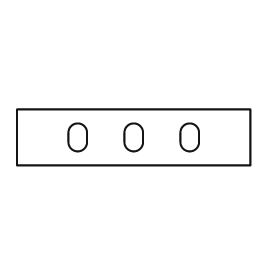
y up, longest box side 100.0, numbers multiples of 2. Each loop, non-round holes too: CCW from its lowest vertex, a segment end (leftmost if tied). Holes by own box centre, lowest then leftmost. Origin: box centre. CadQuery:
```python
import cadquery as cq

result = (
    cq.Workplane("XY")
    .moveTo(-50.0, -12.0)
    .lineTo(50.0, -12.0)
    .lineTo(50.0, 12.0)
    .lineTo(-50.0, 12.0)
    .close()
    .moveTo(-28.0, -2.0)
    .threePointArc((-24.0, -6.0), (-20.0, -2.0))
    .lineTo(-20.0, 2.0)
    .threePointArc((-24.0, 6.0), (-28.0, 2.0))
    .close()
    .moveTo(-4.0, -2.0)
    .threePointArc((0.0, -6.0), (4.0, -2.0))
    .lineTo(4.0, 2.0)
    .threePointArc((0.0, 6.0), (-4.0, 2.0))
    .close()
    .moveTo(20.0, -2.0)
    .threePointArc((24.0, -6.0), (28.0, -2.0))
    .lineTo(28.0, 2.0)
    .threePointArc((24.0, 6.0), (20.0, 2.0))
    .close()
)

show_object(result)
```